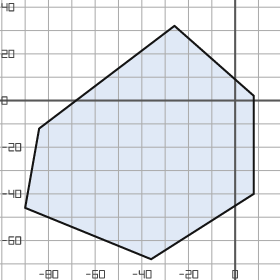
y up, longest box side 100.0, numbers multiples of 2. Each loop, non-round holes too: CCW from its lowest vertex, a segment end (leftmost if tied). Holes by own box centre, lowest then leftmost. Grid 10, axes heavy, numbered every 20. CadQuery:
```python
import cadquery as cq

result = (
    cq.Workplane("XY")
    .moveTo(-36.0, -68.0)
    .lineTo(8.0, -40.0)
    .lineTo(8.0, 2.0)
    .lineTo(-26.0, 32.0)
    .lineTo(-84.0, -12.0)
    .lineTo(-90.0, -46.0)
    .close()
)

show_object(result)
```